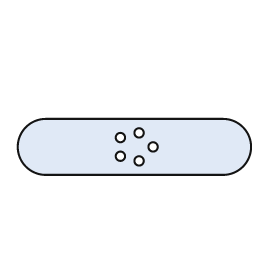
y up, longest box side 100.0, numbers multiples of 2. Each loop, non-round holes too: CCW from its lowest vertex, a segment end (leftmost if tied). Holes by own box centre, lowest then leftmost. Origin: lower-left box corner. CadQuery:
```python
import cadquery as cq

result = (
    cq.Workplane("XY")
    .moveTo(12.0, 0.0)
    .lineTo(88.0, 0.0)
    .threePointArc((100.0, 12.0), (88.0, 24.0))
    .lineTo(12.0, 24.0)
    .threePointArc((0.0, 12.0), (12.0, 0.0))
    .close()
    .moveTo(52.0, 6.0)
    .circle(2.0)
    .moveTo(44.0, 8.0)
    .circle(2.0)
    .moveTo(58.0, 12.0)
    .circle(2.0)
    .moveTo(44.0, 16.0)
    .circle(2.0)
    .moveTo(52.0, 18.0)
    .circle(2.0)
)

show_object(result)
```